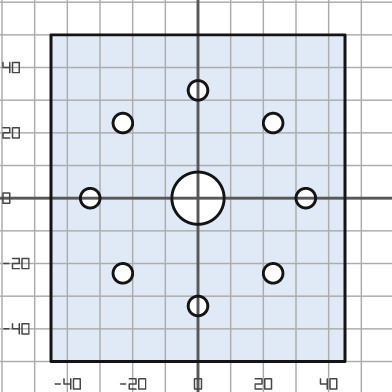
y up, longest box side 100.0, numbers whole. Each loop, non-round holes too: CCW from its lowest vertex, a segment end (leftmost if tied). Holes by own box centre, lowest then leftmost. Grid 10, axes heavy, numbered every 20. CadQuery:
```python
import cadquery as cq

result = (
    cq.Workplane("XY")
    .moveTo(-45.0, -50.0)
    .lineTo(45.0, -50.0)
    .lineTo(45.0, 50.0)
    .lineTo(-45.0, 50.0)
    .close()
    .moveTo(0.0, -33.0)
    .circle(3.0)
    .moveTo(-23.0, -23.0)
    .circle(3.0)
    .moveTo(23.0, -23.0)
    .circle(3.0)
    .moveTo(-33.0, 0.0)
    .circle(3.0)
    .moveTo(0.0, 0.0)
    .circle(8.0)
    .moveTo(33.0, 0.0)
    .circle(3.0)
    .moveTo(-23.0, 23.0)
    .circle(3.0)
    .moveTo(23.0, 23.0)
    .circle(3.0)
    .moveTo(0.0, 33.0)
    .circle(3.0)
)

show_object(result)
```